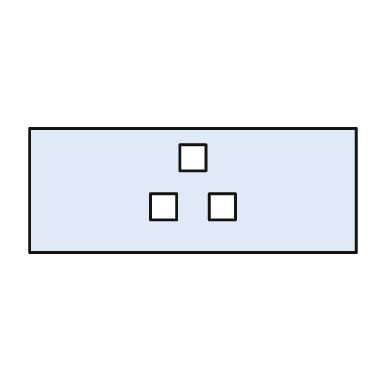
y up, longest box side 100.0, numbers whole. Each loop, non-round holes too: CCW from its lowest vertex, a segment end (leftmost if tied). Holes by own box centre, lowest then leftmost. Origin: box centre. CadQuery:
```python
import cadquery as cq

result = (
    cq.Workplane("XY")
    .moveTo(-50.0, -19.0)
    .lineTo(50.0, -19.0)
    .lineTo(50.0, 19.0)
    .lineTo(-50.0, 19.0)
    .close()
    .moveTo(-13.0, -9.0)
    .lineTo(-5.0, -9.0)
    .lineTo(-5.0, -1.0)
    .lineTo(-13.0, -1.0)
    .close()
    .moveTo(5.0, -9.0)
    .lineTo(13.0, -9.0)
    .lineTo(13.0, -1.0)
    .lineTo(5.0, -1.0)
    .close()
    .moveTo(-4.0, 6.0)
    .lineTo(4.0, 6.0)
    .lineTo(4.0, 14.0)
    .lineTo(-4.0, 14.0)
    .close()
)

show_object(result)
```